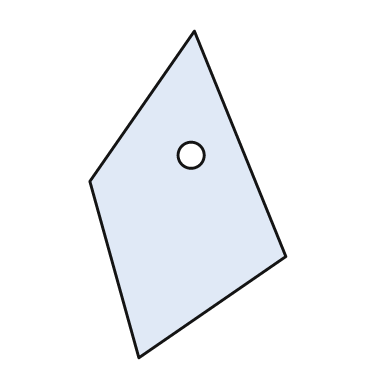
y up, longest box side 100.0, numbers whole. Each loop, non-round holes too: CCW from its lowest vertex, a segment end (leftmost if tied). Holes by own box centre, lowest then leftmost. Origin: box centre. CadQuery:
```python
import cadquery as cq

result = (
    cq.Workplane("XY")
    .moveTo(-15.0, -50.0)
    .lineTo(30.0, -19.0)
    .lineTo(2.0, 50.0)
    .lineTo(-30.0, 4.0)
    .close()
    .moveTo(1.0, 12.0)
    .circle(4.0)
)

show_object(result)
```